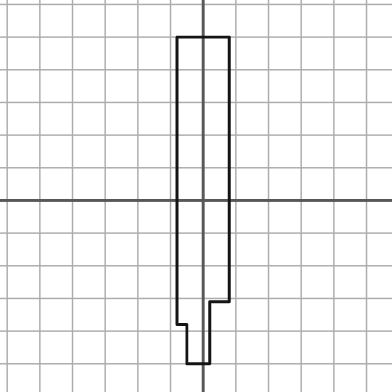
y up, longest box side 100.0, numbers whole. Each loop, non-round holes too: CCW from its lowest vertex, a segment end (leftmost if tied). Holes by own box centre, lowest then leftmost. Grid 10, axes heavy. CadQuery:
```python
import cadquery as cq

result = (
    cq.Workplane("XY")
    .moveTo(-5.0, -50.0)
    .lineTo(2.0, -50.0)
    .lineTo(2.0, -31.0)
    .lineTo(8.0, -31.0)
    .lineTo(8.0, 50.0)
    .lineTo(-8.0, 50.0)
    .lineTo(-8.0, -38.0)
    .lineTo(-5.0, -38.0)
    .close()
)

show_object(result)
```